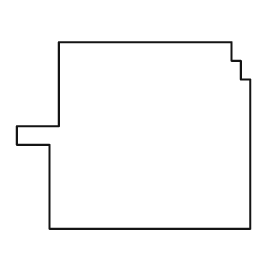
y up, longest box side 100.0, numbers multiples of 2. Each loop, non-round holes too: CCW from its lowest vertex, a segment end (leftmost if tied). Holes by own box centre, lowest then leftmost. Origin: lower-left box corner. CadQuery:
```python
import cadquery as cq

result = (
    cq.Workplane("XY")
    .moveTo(14.0, 0.0)
    .lineTo(100.0, 0.0)
    .lineTo(100.0, 64.0)
    .lineTo(96.0, 64.0)
    .lineTo(96.0, 72.0)
    .lineTo(92.0, 72.0)
    .lineTo(92.0, 80.0)
    .lineTo(18.0, 80.0)
    .lineTo(18.0, 44.0)
    .lineTo(0.0, 44.0)
    .lineTo(0.0, 36.0)
    .lineTo(14.0, 36.0)
    .close()
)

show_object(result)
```